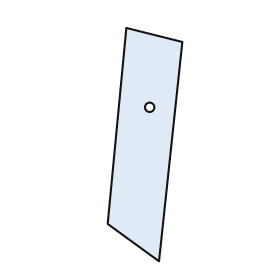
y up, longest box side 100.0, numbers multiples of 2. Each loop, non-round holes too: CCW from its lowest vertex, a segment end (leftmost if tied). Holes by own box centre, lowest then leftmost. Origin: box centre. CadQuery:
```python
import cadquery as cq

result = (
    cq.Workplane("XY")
    .moveTo(6.0, -50.0)
    .lineTo(16.0, 44.0)
    .lineTo(-8.0, 50.0)
    .lineTo(-16.0, -34.0)
    .close()
    .moveTo(2.0, 16.0)
    .circle(2.0)
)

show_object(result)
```